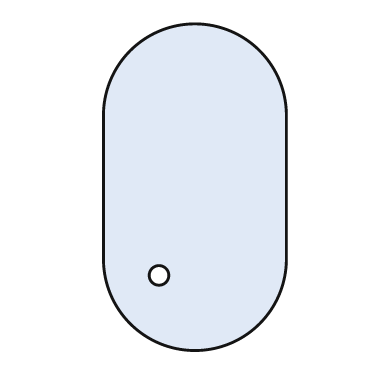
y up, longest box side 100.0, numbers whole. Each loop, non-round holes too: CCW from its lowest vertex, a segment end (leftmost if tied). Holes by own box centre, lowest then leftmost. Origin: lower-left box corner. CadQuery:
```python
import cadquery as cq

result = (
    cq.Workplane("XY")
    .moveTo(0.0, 28.0)
    .threePointArc((28.0, 0.0), (56.0, 28.0))
    .lineTo(56.0, 72.0)
    .threePointArc((28.0, 100.0), (0.0, 72.0))
    .close()
    .moveTo(17.0, 23.0)
    .circle(3.0)
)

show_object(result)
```